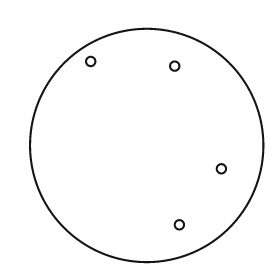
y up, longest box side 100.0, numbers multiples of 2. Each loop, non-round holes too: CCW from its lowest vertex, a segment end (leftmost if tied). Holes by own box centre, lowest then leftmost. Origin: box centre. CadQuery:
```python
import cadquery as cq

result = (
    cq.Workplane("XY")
    .moveTo(0.0, 0.0)
    .circle(50.0)
    .moveTo(14.0, -34.0)
    .circle(2.0)
    .moveTo(32.0, -10.0)
    .circle(2.0)
    .moveTo(12.0, 34.0)
    .circle(2.0)
    .moveTo(-24.0, 36.0)
    .circle(2.0)
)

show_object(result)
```